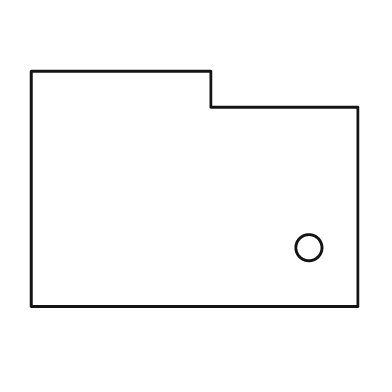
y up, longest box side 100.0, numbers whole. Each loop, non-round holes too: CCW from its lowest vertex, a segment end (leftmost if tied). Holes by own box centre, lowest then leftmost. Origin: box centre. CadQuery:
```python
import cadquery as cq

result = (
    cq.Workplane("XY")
    .moveTo(-50.0, -36.0)
    .lineTo(50.0, -36.0)
    .lineTo(50.0, 25.0)
    .lineTo(5.0, 25.0)
    .lineTo(5.0, 36.0)
    .lineTo(-50.0, 36.0)
    .close()
    .moveTo(35.0, -18.0)
    .circle(4.0)
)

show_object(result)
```